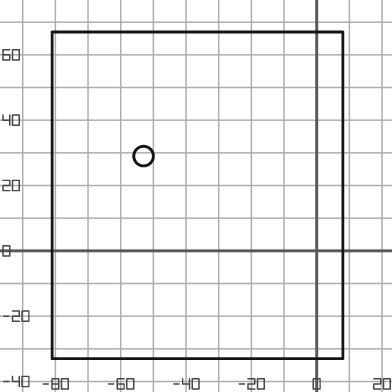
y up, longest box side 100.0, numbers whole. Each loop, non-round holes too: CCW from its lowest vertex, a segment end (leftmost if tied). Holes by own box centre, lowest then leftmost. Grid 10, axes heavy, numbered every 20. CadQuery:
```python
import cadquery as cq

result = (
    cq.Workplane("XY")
    .moveTo(-81.0, -33.0)
    .lineTo(8.0, -33.0)
    .lineTo(8.0, 67.0)
    .lineTo(-81.0, 67.0)
    .close()
    .moveTo(-53.0, 29.0)
    .circle(3.0)
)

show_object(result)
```